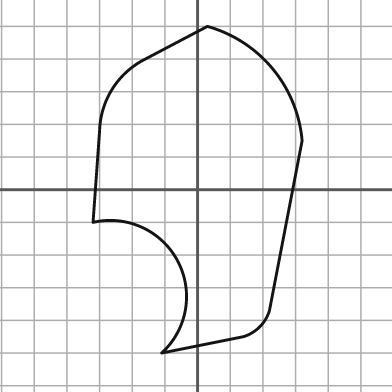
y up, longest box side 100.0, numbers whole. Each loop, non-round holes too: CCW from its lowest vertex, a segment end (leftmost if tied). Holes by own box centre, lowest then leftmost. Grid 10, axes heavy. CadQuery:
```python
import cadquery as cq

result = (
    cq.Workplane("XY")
    .moveTo(-11.0, -50.0)
    .lineTo(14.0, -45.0)
    .threePointArc((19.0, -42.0), (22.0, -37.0))
    .lineTo(32.0, 15.0)
    .threePointArc((23.0, 37.0), (3.0, 50.0))
    .lineTo(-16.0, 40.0)
    .threePointArc((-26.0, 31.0), (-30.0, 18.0))
    .lineTo(-32.0, -10.0)
    .threePointArc((-6.0, -22.0), (-11.0, -50.0))
    .close()
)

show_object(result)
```